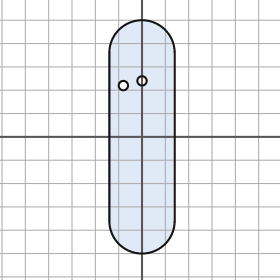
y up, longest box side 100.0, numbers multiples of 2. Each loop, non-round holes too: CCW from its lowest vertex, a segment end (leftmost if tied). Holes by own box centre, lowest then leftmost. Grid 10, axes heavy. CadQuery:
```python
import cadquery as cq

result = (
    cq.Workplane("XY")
    .moveTo(-14.0, -36.0)
    .threePointArc((0.0, -50.0), (14.0, -36.0))
    .lineTo(14.0, 36.0)
    .threePointArc((0.0, 50.0), (-14.0, 36.0))
    .close()
    .moveTo(-8.0, 22.0)
    .circle(2.0)
    .moveTo(0.0, 24.0)
    .circle(2.0)
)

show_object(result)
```